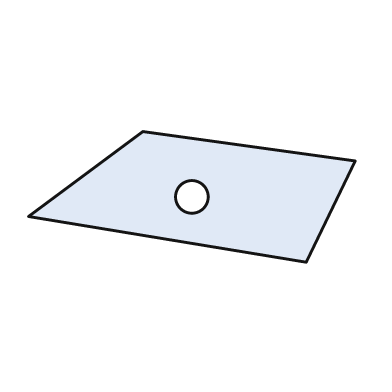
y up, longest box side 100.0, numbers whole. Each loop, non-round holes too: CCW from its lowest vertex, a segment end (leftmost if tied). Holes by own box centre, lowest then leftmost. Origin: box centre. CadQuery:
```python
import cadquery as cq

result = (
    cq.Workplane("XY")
    .moveTo(35.0, -20.0)
    .lineTo(50.0, 11.0)
    .lineTo(-15.0, 20.0)
    .lineTo(-50.0, -6.0)
    .close()
    .moveTo(0.0, 0.0)
    .circle(5.0)
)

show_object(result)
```